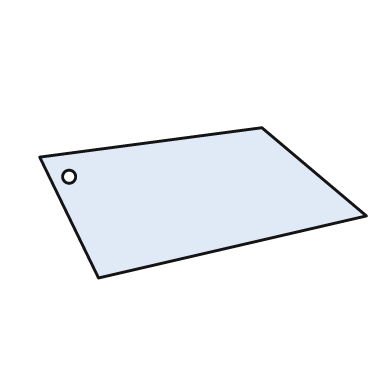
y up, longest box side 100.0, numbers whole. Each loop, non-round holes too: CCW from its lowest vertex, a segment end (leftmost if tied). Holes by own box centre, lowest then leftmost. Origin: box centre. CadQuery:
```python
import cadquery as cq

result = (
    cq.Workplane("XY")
    .moveTo(-32.0, -23.0)
    .lineTo(50.0, -4.0)
    .lineTo(18.0, 23.0)
    .lineTo(-50.0, 14.0)
    .close()
    .moveTo(-41.0, 8.0)
    .circle(2.0)
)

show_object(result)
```